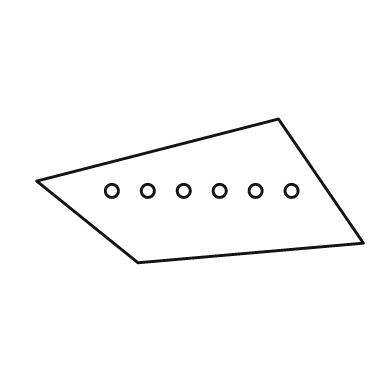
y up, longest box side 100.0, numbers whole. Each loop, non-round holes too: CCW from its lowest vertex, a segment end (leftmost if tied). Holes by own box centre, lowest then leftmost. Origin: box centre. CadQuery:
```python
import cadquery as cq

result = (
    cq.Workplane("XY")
    .moveTo(-19.0, -22.0)
    .lineTo(50.0, -16.0)
    .lineTo(24.0, 22.0)
    .lineTo(-50.0, 3.0)
    .close()
    .moveTo(-27.0, 0.0)
    .circle(2.0)
    .moveTo(-16.0, 0.0)
    .circle(2.0)
    .moveTo(-5.0, 0.0)
    .circle(2.0)
    .moveTo(6.0, 0.0)
    .circle(2.0)
    .moveTo(17.0, 0.0)
    .circle(2.0)
    .moveTo(28.0, 0.0)
    .circle(2.0)
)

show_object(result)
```